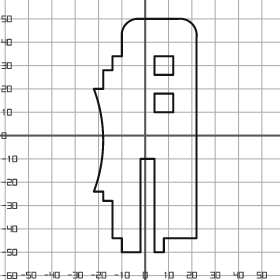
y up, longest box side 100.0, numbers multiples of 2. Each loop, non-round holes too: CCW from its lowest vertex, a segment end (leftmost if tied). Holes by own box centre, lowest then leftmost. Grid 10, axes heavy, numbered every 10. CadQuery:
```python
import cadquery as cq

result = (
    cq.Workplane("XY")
    .moveTo(-10.0, -50.0)
    .lineTo(-2.0, -50.0)
    .lineTo(-2.0, -10.0)
    .lineTo(4.0, -10.0)
    .lineTo(4.0, -50.0)
    .lineTo(8.0, -50.0)
    .lineTo(8.0, -44.0)
    .lineTo(22.0, -44.0)
    .lineTo(22.0, 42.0)
    .threePointArc((20.0, 48.0), (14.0, 50.0))
    .lineTo(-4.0, 50.0)
    .threePointArc((-8.0, 48.0), (-10.0, 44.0))
    .lineTo(-10.0, 34.0)
    .lineTo(-14.0, 34.0)
    .lineTo(-14.0, 28.0)
    .lineTo(-18.0, 28.0)
    .lineTo(-18.0, 20.0)
    .lineTo(-22.0, 20.0)
    .threePointArc((-18.0, -2.0), (-22.0, -24.0))
    .lineTo(-18.0, -24.0)
    .lineTo(-18.0, -28.0)
    .lineTo(-14.0, -28.0)
    .lineTo(-14.0, -44.0)
    .lineTo(-10.0, -44.0)
    .close()
    .moveTo(4.0, 10.0)
    .lineTo(12.0, 10.0)
    .lineTo(12.0, 18.0)
    .lineTo(4.0, 18.0)
    .close()
    .moveTo(4.0, 26.0)
    .lineTo(12.0, 26.0)
    .lineTo(12.0, 34.0)
    .lineTo(4.0, 34.0)
    .close()
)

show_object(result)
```